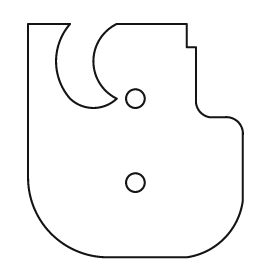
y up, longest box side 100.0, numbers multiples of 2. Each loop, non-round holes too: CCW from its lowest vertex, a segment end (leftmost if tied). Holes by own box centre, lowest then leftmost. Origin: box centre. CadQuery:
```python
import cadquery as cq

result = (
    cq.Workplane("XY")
    .moveTo(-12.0, -50.0)
    .lineTo(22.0, -50.0)
    .threePointArc((38.0, -42.0), (46.0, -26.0))
    .lineTo(46.0, 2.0)
    .threePointArc((44.0, 8.0), (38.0, 10.0))
    .lineTo(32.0, 10.0)
    .threePointArc((28.0, 12.0), (26.0, 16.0))
    .lineTo(26.0, 40.0)
    .lineTo(22.0, 40.0)
    .lineTo(22.0, 50.0)
    .lineTo(-8.0, 50.0)
    .threePointArc((-18.0, 34.0), (-8.0, 18.0))
    .threePointArc((-18.0, 14.0), (-28.0, 18.0))
    .threePointArc((-34.0, 34.0), (-28.0, 50.0))
    .lineTo(-46.0, 50.0)
    .lineTo(-46.0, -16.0)
    .threePointArc((-36.0, -40.0), (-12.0, -50.0))
    .close()
    .moveTo(0.0, -18.0)
    .circle(4.0)
    .moveTo(0.0, 18.0)
    .circle(4.0)
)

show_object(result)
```